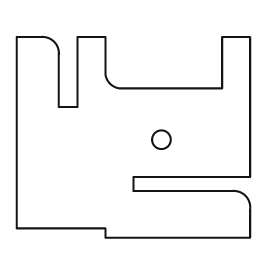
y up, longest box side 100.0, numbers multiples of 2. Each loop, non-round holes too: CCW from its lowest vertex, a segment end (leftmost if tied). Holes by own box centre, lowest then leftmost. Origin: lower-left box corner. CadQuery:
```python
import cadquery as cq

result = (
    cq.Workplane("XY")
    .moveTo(38.0, 0.0)
    .lineTo(100.0, 0.0)
    .lineTo(100.0, 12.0)
    .threePointArc((98.0, 18.0), (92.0, 20.0))
    .lineTo(50.0, 20.0)
    .lineTo(50.0, 26.0)
    .lineTo(100.0, 26.0)
    .lineTo(100.0, 86.0)
    .lineTo(88.0, 86.0)
    .lineTo(88.0, 64.0)
    .lineTo(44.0, 64.0)
    .threePointArc((40.0, 66.0), (38.0, 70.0))
    .lineTo(38.0, 86.0)
    .lineTo(26.0, 86.0)
    .lineTo(26.0, 56.0)
    .lineTo(18.0, 56.0)
    .lineTo(18.0, 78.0)
    .threePointArc((16.0, 84.0), (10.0, 86.0))
    .lineTo(0.0, 86.0)
    .lineTo(0.0, 4.0)
    .lineTo(38.0, 4.0)
    .close()
    .moveTo(62.0, 42.0)
    .circle(4.0)
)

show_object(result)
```